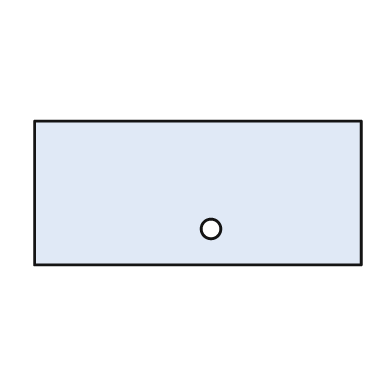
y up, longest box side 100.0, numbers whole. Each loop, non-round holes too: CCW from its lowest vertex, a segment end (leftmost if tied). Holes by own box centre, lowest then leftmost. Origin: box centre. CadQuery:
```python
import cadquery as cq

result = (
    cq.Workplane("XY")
    .moveTo(-50.0, -22.0)
    .lineTo(50.0, -22.0)
    .lineTo(50.0, 22.0)
    .lineTo(-50.0, 22.0)
    .close()
    .moveTo(4.0, -11.0)
    .circle(3.0)
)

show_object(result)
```